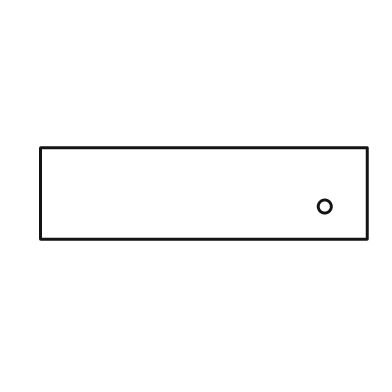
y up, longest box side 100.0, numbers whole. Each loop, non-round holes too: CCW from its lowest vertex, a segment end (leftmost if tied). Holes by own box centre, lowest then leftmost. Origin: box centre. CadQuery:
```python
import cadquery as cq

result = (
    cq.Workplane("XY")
    .moveTo(-50.0, -14.0)
    .lineTo(50.0, -14.0)
    .lineTo(50.0, 14.0)
    .lineTo(-50.0, 14.0)
    .close()
    .moveTo(37.0, -4.0)
    .circle(2.0)
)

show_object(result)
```